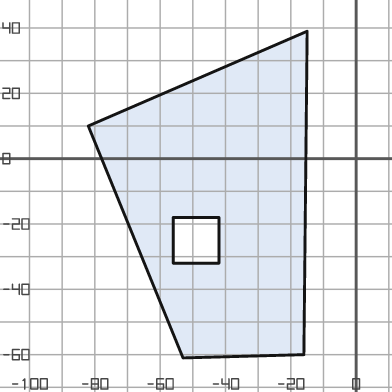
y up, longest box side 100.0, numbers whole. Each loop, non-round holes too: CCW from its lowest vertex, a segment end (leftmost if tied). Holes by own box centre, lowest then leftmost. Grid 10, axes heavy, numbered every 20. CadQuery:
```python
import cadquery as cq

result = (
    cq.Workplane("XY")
    .moveTo(-53.0, -61.0)
    .lineTo(-16.0, -60.0)
    .lineTo(-15.0, 39.0)
    .lineTo(-82.0, 10.0)
    .close()
    .moveTo(-56.0, -32.0)
    .lineTo(-42.0, -32.0)
    .lineTo(-42.0, -18.0)
    .lineTo(-56.0, -18.0)
    .close()
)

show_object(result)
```